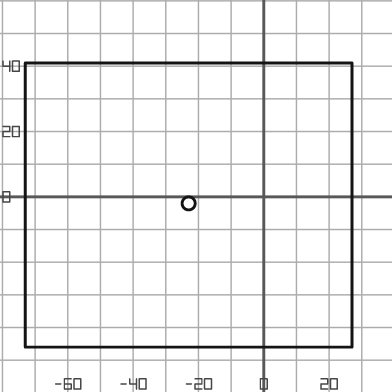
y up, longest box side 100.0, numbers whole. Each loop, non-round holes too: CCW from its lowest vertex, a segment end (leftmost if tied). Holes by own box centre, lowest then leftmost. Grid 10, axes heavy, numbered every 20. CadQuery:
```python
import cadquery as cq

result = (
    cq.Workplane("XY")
    .moveTo(-73.0, -46.0)
    .lineTo(27.0, -46.0)
    .lineTo(27.0, 41.0)
    .lineTo(-73.0, 41.0)
    .close()
    .moveTo(-23.0, -2.0)
    .circle(2.0)
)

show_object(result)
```